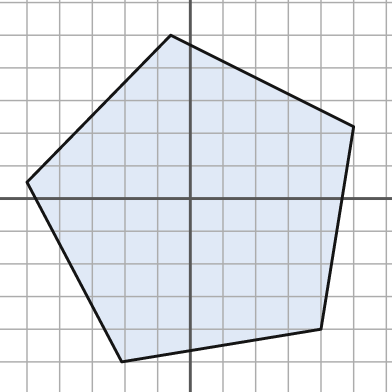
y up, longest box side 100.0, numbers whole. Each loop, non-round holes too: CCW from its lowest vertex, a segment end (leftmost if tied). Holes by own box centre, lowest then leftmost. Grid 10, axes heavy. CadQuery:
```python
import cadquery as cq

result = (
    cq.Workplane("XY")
    .moveTo(-21.0, -50.0)
    .lineTo(40.0, -40.0)
    .lineTo(50.0, 22.0)
    .lineTo(-6.0, 50.0)
    .lineTo(-50.0, 5.0)
    .close()
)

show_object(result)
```